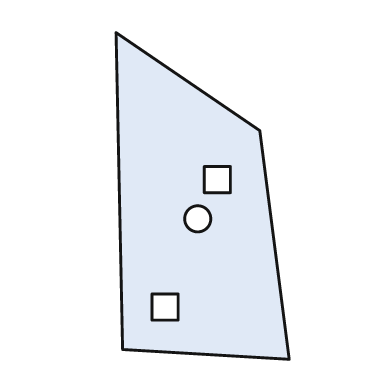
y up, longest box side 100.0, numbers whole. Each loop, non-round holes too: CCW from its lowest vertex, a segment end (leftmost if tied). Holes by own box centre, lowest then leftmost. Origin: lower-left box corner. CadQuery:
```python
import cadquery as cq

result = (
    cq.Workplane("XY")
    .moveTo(53.0, 0.0)
    .lineTo(44.0, 70.0)
    .lineTo(0.0, 100.0)
    .lineTo(2.0, 3.0)
    .close()
    .moveTo(11.0, 12.0)
    .lineTo(19.0, 12.0)
    .lineTo(19.0, 20.0)
    .lineTo(11.0, 20.0)
    .close()
    .moveTo(25.0, 43.0)
    .circle(4.0)
    .moveTo(27.0, 51.0)
    .lineTo(35.0, 51.0)
    .lineTo(35.0, 59.0)
    .lineTo(27.0, 59.0)
    .close()
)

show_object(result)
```